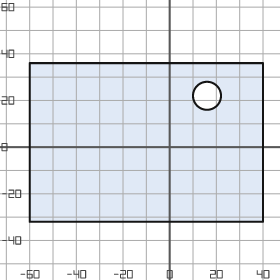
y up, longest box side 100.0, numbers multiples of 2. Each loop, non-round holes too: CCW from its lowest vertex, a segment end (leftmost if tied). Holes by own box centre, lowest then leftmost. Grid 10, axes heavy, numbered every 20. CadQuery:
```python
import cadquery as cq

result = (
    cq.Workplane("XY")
    .moveTo(-60.0, -32.0)
    .lineTo(40.0, -32.0)
    .lineTo(40.0, 36.0)
    .lineTo(-60.0, 36.0)
    .close()
    .moveTo(16.0, 22.0)
    .circle(6.0)
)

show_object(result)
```